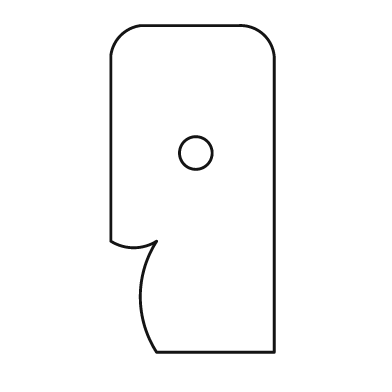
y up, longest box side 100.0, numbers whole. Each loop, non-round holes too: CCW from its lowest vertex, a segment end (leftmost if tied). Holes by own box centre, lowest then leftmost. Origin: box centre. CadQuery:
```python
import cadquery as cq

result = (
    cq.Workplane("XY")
    .moveTo(-11.0, -50.0)
    .lineTo(25.0, -50.0)
    .lineTo(25.0, 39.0)
    .threePointArc((22.0, 47.0), (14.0, 50.0))
    .lineTo(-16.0, 50.0)
    .threePointArc((-22.0, 47.0), (-25.0, 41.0))
    .lineTo(-25.0, -16.0)
    .threePointArc((-18.0, -18.0), (-11.0, -16.0))
    .threePointArc((-16.0, -33.0), (-11.0, -50.0))
    .close()
    .moveTo(1.0, 11.0)
    .circle(5.0)
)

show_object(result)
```